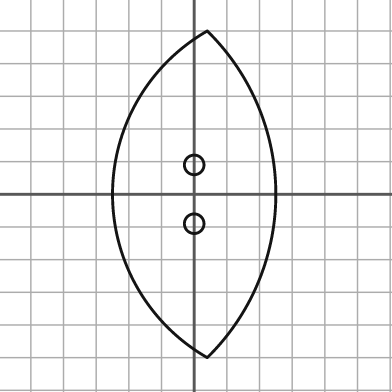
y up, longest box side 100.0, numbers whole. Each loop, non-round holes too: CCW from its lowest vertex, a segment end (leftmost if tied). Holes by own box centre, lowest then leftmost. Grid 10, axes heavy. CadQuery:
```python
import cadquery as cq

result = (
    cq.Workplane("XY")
    .moveTo(4.0, -50.0)
    .threePointArc((25.0, 0.0), (4.0, 50.0))
    .threePointArc((-25.0, 0.0), (4.0, -50.0))
    .close()
    .moveTo(0.0, -9.0)
    .circle(3.0)
    .moveTo(0.0, 9.0)
    .circle(3.0)
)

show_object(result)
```